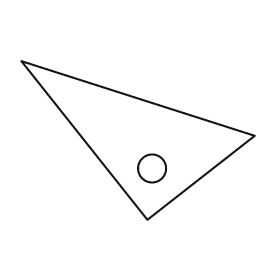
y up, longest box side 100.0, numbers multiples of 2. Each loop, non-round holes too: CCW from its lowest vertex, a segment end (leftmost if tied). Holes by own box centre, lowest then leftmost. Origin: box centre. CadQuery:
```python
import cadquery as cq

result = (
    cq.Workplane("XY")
    .moveTo(4.0, -34.0)
    .lineTo(50.0, 2.0)
    .lineTo(-50.0, 34.0)
    .close()
    .moveTo(6.0, -12.0)
    .circle(6.0)
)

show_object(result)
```